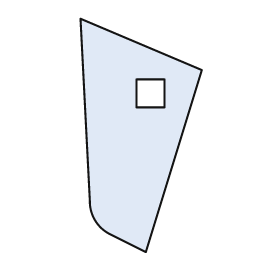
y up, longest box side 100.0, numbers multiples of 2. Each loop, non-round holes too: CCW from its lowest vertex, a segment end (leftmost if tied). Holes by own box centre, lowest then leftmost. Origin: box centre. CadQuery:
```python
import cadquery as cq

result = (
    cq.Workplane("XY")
    .moveTo(2.0, -50.0)
    .lineTo(26.0, 28.0)
    .lineTo(-26.0, 50.0)
    .lineTo(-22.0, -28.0)
    .threePointArc((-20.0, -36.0), (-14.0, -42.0))
    .close()
    .moveTo(-2.0, 12.0)
    .lineTo(10.0, 12.0)
    .lineTo(10.0, 24.0)
    .lineTo(-2.0, 24.0)
    .close()
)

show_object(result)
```